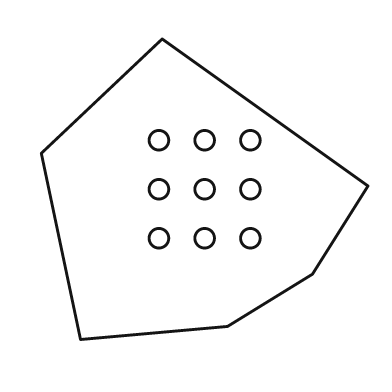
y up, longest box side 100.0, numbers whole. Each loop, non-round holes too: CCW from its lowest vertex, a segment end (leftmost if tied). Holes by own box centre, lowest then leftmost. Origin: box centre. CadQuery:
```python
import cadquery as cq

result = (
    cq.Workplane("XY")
    .moveTo(-38.0, -46.0)
    .lineTo(7.0, -42.0)
    .lineTo(33.0, -26.0)
    .lineTo(50.0, 1.0)
    .lineTo(-13.0, 46.0)
    .lineTo(-50.0, 11.0)
    .close()
    .moveTo(-14.0, -15.0)
    .circle(3.0)
    .moveTo(0.0, -15.0)
    .circle(3.0)
    .moveTo(14.0, -15.0)
    .circle(3.0)
    .moveTo(-14.0, 0.0)
    .circle(3.0)
    .moveTo(0.0, 0.0)
    .circle(3.0)
    .moveTo(14.0, 0.0)
    .circle(3.0)
    .moveTo(-14.0, 15.0)
    .circle(3.0)
    .moveTo(0.0, 15.0)
    .circle(3.0)
    .moveTo(14.0, 15.0)
    .circle(3.0)
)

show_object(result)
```